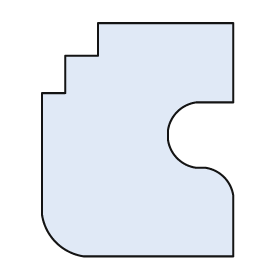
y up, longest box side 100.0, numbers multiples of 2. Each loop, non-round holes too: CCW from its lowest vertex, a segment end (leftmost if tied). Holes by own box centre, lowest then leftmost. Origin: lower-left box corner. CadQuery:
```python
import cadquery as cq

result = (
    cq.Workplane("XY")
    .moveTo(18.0, 0.0)
    .lineTo(82.0, 0.0)
    .lineTo(82.0, 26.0)
    .threePointArc((78.0, 34.0), (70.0, 38.0))
    .lineTo(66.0, 38.0)
    .threePointArc((58.0, 42.0), (54.0, 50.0))
    .lineTo(54.0, 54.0)
    .threePointArc((58.0, 62.0), (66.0, 66.0))
    .lineTo(82.0, 66.0)
    .lineTo(82.0, 100.0)
    .lineTo(24.0, 100.0)
    .lineTo(24.0, 86.0)
    .lineTo(10.0, 86.0)
    .lineTo(10.0, 70.0)
    .lineTo(0.0, 70.0)
    .lineTo(0.0, 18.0)
    .threePointArc((6.0, 6.0), (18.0, 0.0))
    .close()
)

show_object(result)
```